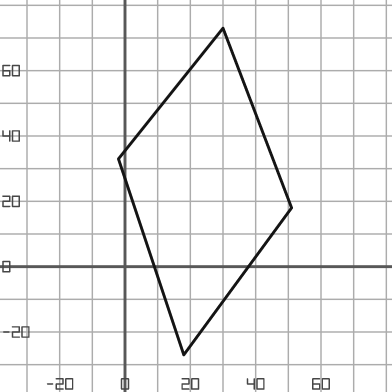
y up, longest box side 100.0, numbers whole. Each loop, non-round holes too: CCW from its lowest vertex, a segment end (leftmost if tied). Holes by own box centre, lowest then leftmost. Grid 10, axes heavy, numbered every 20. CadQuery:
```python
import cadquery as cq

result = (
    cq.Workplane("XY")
    .moveTo(18.0, -27.0)
    .lineTo(51.0, 18.0)
    .lineTo(30.0, 73.0)
    .lineTo(-2.0, 33.0)
    .close()
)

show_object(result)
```